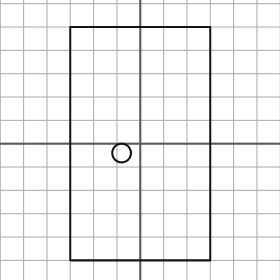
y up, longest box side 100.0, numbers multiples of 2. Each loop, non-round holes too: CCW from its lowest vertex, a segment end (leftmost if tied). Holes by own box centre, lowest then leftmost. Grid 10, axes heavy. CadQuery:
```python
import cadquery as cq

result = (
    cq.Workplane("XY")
    .moveTo(-30.0, -50.0)
    .lineTo(30.0, -50.0)
    .lineTo(30.0, 50.0)
    .lineTo(-30.0, 50.0)
    .close()
    .moveTo(-8.0, -4.0)
    .circle(4.0)
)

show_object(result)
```